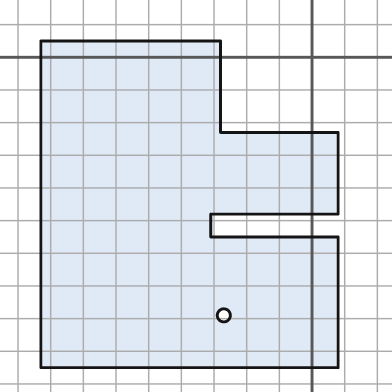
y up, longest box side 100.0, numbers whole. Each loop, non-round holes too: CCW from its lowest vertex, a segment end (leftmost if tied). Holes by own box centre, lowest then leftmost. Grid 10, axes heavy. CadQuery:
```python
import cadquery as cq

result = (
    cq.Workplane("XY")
    .moveTo(-83.0, -95.0)
    .lineTo(8.0, -95.0)
    .lineTo(8.0, -55.0)
    .lineTo(-31.0, -55.0)
    .lineTo(-31.0, -48.0)
    .lineTo(8.0, -48.0)
    .lineTo(8.0, -23.0)
    .lineTo(-28.0, -23.0)
    .lineTo(-28.0, 5.0)
    .lineTo(-83.0, 5.0)
    .close()
    .moveTo(-27.0, -79.0)
    .circle(2.0)
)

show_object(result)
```